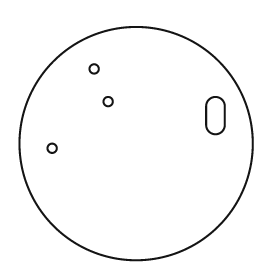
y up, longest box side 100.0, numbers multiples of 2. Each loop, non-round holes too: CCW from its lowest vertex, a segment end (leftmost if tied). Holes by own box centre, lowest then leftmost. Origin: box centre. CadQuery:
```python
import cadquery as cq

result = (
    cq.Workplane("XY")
    .moveTo(0.0, 0.0)
    .circle(50.0)
    .moveTo(-36.0, -2.0)
    .circle(2.0)
    .moveTo(30.0, 8.0)
    .threePointArc((34.0, 4.0), (38.0, 8.0))
    .lineTo(38.0, 16.0)
    .threePointArc((34.0, 20.0), (30.0, 16.0))
    .close()
    .moveTo(-12.0, 18.0)
    .circle(2.0)
    .moveTo(-18.0, 32.0)
    .circle(2.0)
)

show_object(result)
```